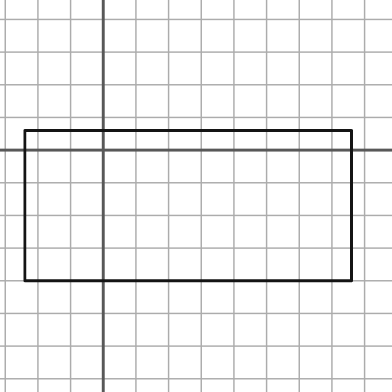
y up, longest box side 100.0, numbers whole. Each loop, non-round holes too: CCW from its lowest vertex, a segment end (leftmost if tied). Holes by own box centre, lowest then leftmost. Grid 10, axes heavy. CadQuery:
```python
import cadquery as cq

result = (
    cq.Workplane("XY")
    .moveTo(-24.0, -40.0)
    .lineTo(76.0, -40.0)
    .lineTo(76.0, 6.0)
    .lineTo(-24.0, 6.0)
    .close()
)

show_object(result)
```